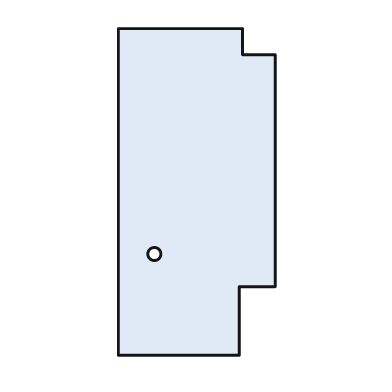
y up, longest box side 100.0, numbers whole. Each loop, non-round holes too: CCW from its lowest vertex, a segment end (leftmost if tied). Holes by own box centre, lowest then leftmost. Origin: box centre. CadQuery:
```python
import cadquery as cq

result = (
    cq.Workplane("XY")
    .moveTo(-24.0, -50.0)
    .lineTo(13.0, -50.0)
    .lineTo(13.0, -29.0)
    .lineTo(24.0, -29.0)
    .lineTo(24.0, 42.0)
    .lineTo(14.0, 42.0)
    .lineTo(14.0, 50.0)
    .lineTo(-24.0, 50.0)
    .close()
    .moveTo(-13.0, -19.0)
    .circle(2.0)
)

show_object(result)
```